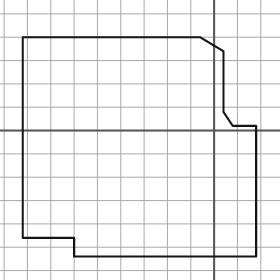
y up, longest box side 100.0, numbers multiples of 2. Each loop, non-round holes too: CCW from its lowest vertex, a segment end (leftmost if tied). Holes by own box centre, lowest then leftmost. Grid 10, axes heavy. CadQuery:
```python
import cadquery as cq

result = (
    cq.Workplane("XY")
    .moveTo(-60.0, -54.0)
    .lineTo(18.0, -54.0)
    .lineTo(18.0, 2.0)
    .lineTo(8.0, 2.0)
    .lineTo(4.0, 8.0)
    .lineTo(4.0, 34.0)
    .lineTo(-6.0, 40.0)
    .lineTo(-82.0, 40.0)
    .lineTo(-82.0, -46.0)
    .lineTo(-60.0, -46.0)
    .close()
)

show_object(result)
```